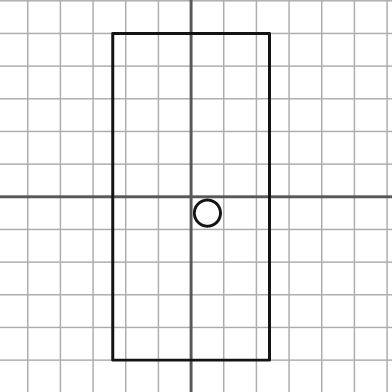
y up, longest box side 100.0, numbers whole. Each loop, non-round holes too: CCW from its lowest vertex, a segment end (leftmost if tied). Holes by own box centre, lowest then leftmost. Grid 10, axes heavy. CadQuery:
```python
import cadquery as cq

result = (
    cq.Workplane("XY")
    .moveTo(-24.0, -50.0)
    .lineTo(24.0, -50.0)
    .lineTo(24.0, 50.0)
    .lineTo(-24.0, 50.0)
    .close()
    .moveTo(5.0, -5.0)
    .circle(4.0)
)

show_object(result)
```